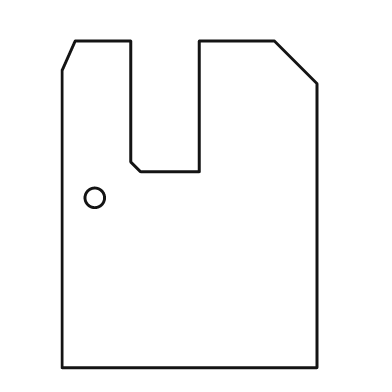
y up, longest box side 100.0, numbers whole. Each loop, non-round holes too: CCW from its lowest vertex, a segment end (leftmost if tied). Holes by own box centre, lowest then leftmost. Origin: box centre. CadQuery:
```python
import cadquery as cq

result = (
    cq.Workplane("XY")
    .moveTo(-39.0, -50.0)
    .lineTo(39.0, -50.0)
    .lineTo(39.0, 37.0)
    .lineTo(26.0, 50.0)
    .lineTo(3.0, 50.0)
    .lineTo(3.0, 10.0)
    .lineTo(-15.0, 10.0)
    .lineTo(-18.0, 13.0)
    .lineTo(-18.0, 50.0)
    .lineTo(-35.0, 50.0)
    .lineTo(-39.0, 41.0)
    .close()
    .moveTo(-29.0, 2.0)
    .circle(3.0)
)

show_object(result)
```